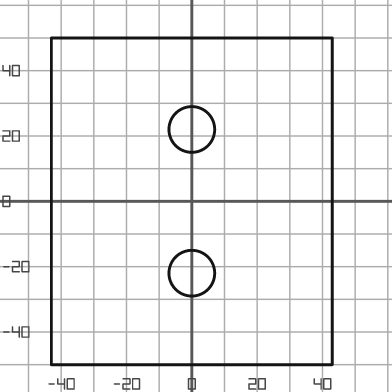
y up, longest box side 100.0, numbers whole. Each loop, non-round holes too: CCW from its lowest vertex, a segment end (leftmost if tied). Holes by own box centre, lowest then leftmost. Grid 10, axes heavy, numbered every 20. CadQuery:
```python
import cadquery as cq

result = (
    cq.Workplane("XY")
    .moveTo(-43.0, -50.0)
    .lineTo(43.0, -50.0)
    .lineTo(43.0, 50.0)
    .lineTo(-43.0, 50.0)
    .close()
    .moveTo(0.0, -22.0)
    .circle(7.0)
    .moveTo(0.0, 22.0)
    .circle(7.0)
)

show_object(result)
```